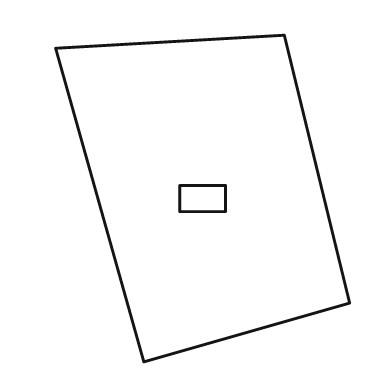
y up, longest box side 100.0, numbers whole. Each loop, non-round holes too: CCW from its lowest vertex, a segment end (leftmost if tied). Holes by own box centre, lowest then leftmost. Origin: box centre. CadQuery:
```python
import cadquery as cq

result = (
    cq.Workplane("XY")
    .moveTo(-18.0, -50.0)
    .lineTo(45.0, -32.0)
    .lineTo(25.0, 50.0)
    .lineTo(-45.0, 46.0)
    .close()
    .moveTo(-7.0, -4.0)
    .lineTo(7.0, -4.0)
    .lineTo(7.0, 4.0)
    .lineTo(-7.0, 4.0)
    .close()
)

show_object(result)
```